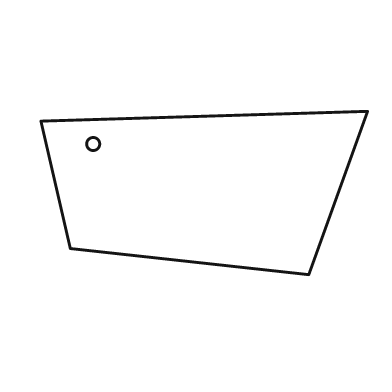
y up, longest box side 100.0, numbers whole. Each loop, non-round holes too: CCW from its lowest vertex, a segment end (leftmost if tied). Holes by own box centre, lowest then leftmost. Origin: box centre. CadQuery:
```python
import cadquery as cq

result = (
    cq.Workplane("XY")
    .moveTo(32.0, -25.0)
    .lineTo(50.0, 25.0)
    .lineTo(-50.0, 22.0)
    .lineTo(-41.0, -17.0)
    .close()
    .moveTo(-34.0, 15.0)
    .circle(2.0)
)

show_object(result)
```